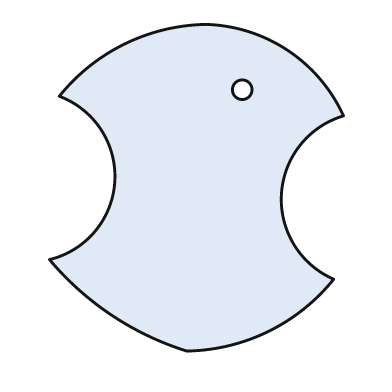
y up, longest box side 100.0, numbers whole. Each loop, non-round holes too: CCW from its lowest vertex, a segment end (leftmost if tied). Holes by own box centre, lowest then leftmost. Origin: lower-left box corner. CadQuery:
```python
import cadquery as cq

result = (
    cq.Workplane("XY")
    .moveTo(42.0, 0.0)
    .threePointArc((67.0, 6.0), (87.0, 22.0))
    .threePointArc((71.0, 48.0), (90.0, 72.0))
    .threePointArc((73.0, 92.0), (48.0, 100.0))
    .threePointArc((23.0, 94.0), (3.0, 78.0))
    .threePointArc((20.0, 52.0), (0.0, 28.0))
    .threePointArc((19.0, 11.0), (42.0, 0.0))
    .close()
    .moveTo(59.0, 80.0)
    .circle(3.0)
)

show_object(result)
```